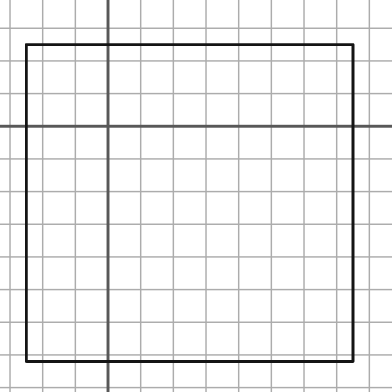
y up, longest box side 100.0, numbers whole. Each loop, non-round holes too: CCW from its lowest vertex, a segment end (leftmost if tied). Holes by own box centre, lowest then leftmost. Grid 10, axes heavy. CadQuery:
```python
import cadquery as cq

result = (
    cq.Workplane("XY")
    .moveTo(-25.0, -72.0)
    .lineTo(75.0, -72.0)
    .lineTo(75.0, 25.0)
    .lineTo(-25.0, 25.0)
    .close()
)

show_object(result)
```